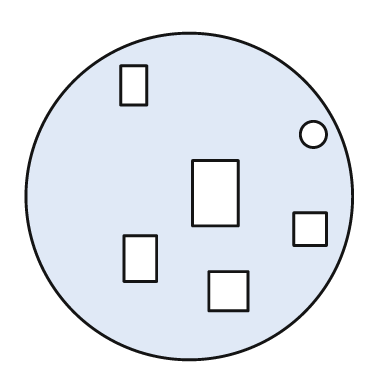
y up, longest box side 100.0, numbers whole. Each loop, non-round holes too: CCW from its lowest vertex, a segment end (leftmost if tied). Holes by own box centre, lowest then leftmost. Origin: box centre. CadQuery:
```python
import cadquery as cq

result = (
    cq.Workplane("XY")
    .moveTo(0.0, 0.0)
    .circle(50.0)
    .moveTo(6.0, -35.0)
    .lineTo(18.0, -35.0)
    .lineTo(18.0, -23.0)
    .lineTo(6.0, -23.0)
    .close()
    .moveTo(-20.0, -26.0)
    .lineTo(-10.0, -26.0)
    .lineTo(-10.0, -12.0)
    .lineTo(-20.0, -12.0)
    .close()
    .moveTo(32.0, -15.0)
    .lineTo(42.0, -15.0)
    .lineTo(42.0, -5.0)
    .lineTo(32.0, -5.0)
    .close()
    .moveTo(1.0, -9.0)
    .lineTo(15.0, -9.0)
    .lineTo(15.0, 11.0)
    .lineTo(1.0, 11.0)
    .close()
    .moveTo(38.0, 19.0)
    .circle(4.0)
    .moveTo(-21.0, 28.0)
    .lineTo(-13.0, 28.0)
    .lineTo(-13.0, 40.0)
    .lineTo(-21.0, 40.0)
    .close()
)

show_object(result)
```